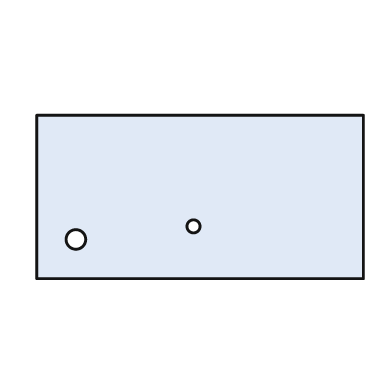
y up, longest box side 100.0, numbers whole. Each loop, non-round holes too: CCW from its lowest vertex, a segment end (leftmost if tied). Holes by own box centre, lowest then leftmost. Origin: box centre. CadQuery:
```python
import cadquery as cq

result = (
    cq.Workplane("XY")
    .moveTo(-50.0, -25.0)
    .lineTo(50.0, -25.0)
    .lineTo(50.0, 25.0)
    .lineTo(-50.0, 25.0)
    .close()
    .moveTo(-38.0, -13.0)
    .circle(3.0)
    .moveTo(-2.0, -9.0)
    .circle(2.0)
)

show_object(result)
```